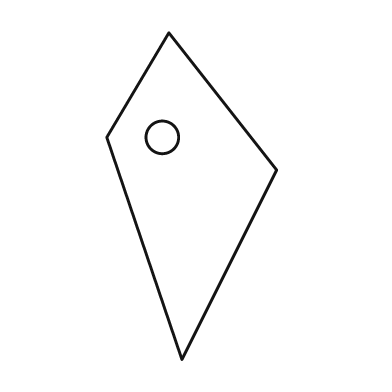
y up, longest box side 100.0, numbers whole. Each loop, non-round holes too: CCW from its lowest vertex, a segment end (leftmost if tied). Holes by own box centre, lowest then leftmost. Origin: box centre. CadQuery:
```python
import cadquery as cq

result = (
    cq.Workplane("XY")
    .moveTo(-3.0, -50.0)
    .lineTo(26.0, 8.0)
    .lineTo(-7.0, 50.0)
    .lineTo(-26.0, 18.0)
    .close()
    .moveTo(-9.0, 18.0)
    .circle(5.0)
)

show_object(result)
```